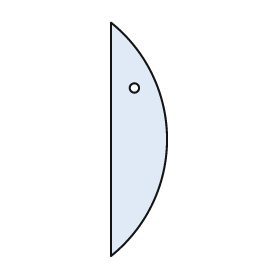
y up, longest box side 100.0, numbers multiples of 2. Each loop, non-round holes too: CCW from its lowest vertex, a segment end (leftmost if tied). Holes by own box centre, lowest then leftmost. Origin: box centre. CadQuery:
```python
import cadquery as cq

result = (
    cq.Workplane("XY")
    .moveTo(-12.0, -50.0)
    .threePointArc((12.0, 0.0), (-12.0, 50.0))
    .close()
    .moveTo(-2.0, 22.0)
    .circle(2.0)
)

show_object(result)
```